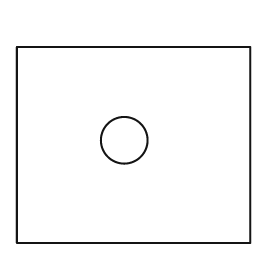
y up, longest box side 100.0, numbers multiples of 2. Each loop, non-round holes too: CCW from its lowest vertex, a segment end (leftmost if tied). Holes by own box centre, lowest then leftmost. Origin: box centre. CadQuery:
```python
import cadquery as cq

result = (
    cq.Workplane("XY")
    .moveTo(-50.0, -42.0)
    .lineTo(50.0, -42.0)
    .lineTo(50.0, 42.0)
    .lineTo(-50.0, 42.0)
    .close()
    .moveTo(-4.0, 2.0)
    .circle(10.0)
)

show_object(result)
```